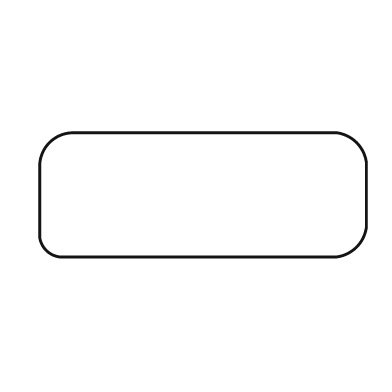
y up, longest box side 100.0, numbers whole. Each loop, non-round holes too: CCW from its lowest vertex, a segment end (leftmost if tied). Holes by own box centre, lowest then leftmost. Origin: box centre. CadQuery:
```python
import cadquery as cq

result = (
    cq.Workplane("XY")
    .moveTo(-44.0, -19.0)
    .lineTo(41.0, -19.0)
    .threePointArc((47.0, -16.0), (50.0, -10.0))
    .lineTo(50.0, 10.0)
    .threePointArc((47.0, 16.0), (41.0, 19.0))
    .lineTo(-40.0, 19.0)
    .threePointArc((-47.0, 16.0), (-50.0, 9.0))
    .lineTo(-50.0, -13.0)
    .threePointArc((-48.0, -17.0), (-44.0, -19.0))
    .close()
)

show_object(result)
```